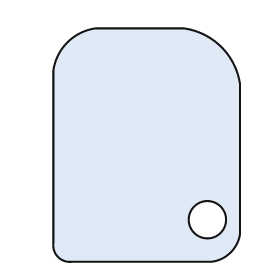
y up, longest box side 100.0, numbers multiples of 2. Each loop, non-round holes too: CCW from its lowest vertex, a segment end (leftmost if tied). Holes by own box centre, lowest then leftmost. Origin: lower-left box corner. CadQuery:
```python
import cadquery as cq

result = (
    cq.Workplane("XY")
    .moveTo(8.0, 0.0)
    .lineTo(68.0, 0.0)
    .threePointArc((76.0, 4.0), (80.0, 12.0))
    .lineTo(80.0, 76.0)
    .threePointArc((72.0, 92.0), (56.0, 100.0))
    .lineTo(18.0, 100.0)
    .threePointArc((6.0, 94.0), (0.0, 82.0))
    .lineTo(0.0, 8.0)
    .threePointArc((2.0, 2.0), (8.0, 0.0))
    .close()
    .moveTo(66.0, 18.0)
    .circle(8.0)
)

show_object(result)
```